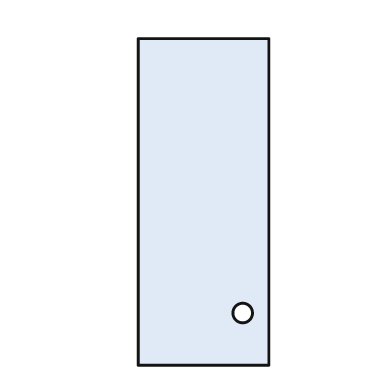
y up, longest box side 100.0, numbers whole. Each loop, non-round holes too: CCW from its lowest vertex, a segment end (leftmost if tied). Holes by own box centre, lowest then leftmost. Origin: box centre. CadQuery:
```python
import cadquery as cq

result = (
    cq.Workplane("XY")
    .moveTo(-20.0, -50.0)
    .lineTo(20.0, -50.0)
    .lineTo(20.0, 50.0)
    .lineTo(-20.0, 50.0)
    .close()
    .moveTo(12.0, -34.0)
    .circle(3.0)
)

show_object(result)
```